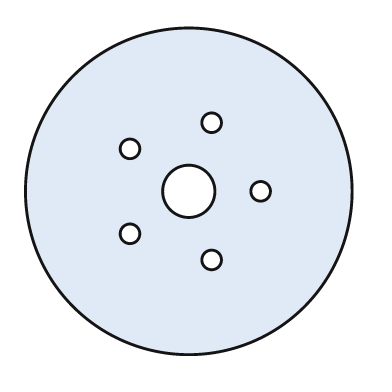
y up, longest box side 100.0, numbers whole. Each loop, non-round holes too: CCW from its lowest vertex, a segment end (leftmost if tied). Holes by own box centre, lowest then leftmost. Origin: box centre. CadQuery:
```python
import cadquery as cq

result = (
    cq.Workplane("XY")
    .moveTo(0.0, 0.0)
    .circle(50.0)
    .moveTo(7.0, -21.0)
    .circle(3.0)
    .moveTo(-18.0, -13.0)
    .circle(3.0)
    .moveTo(0.0, 0.0)
    .circle(8.0)
    .moveTo(22.0, 0.0)
    .circle(3.0)
    .moveTo(-18.0, 13.0)
    .circle(3.0)
    .moveTo(7.0, 21.0)
    .circle(3.0)
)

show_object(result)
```